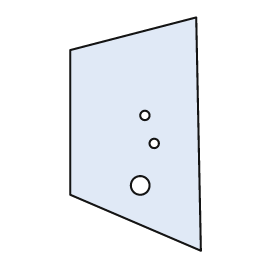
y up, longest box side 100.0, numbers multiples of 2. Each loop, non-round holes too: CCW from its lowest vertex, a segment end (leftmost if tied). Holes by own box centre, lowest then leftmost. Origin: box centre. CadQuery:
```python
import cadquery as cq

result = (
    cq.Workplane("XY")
    .moveTo(28.0, -50.0)
    .lineTo(26.0, 50.0)
    .lineTo(-28.0, 36.0)
    .lineTo(-28.0, -26.0)
    .close()
    .moveTo(2.0, -22.0)
    .circle(4.0)
    .moveTo(8.0, -4.0)
    .circle(2.0)
    .moveTo(4.0, 8.0)
    .circle(2.0)
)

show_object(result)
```